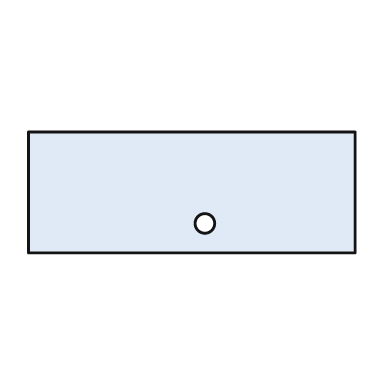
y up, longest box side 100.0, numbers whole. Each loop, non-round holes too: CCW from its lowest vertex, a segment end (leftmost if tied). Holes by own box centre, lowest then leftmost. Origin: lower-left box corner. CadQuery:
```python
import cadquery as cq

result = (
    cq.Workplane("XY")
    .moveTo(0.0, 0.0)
    .lineTo(100.0, 0.0)
    .lineTo(100.0, 37.0)
    .lineTo(0.0, 37.0)
    .close()
    .moveTo(54.0, 9.0)
    .circle(3.0)
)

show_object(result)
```